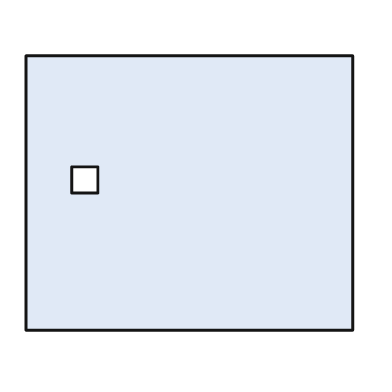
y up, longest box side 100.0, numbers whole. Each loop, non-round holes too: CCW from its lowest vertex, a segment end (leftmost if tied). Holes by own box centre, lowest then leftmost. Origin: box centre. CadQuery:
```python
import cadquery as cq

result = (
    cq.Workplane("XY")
    .moveTo(-50.0, -42.0)
    .lineTo(50.0, -42.0)
    .lineTo(50.0, 42.0)
    .lineTo(-50.0, 42.0)
    .close()
    .moveTo(-36.0, 0.0)
    .lineTo(-28.0, 0.0)
    .lineTo(-28.0, 8.0)
    .lineTo(-36.0, 8.0)
    .close()
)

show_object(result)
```